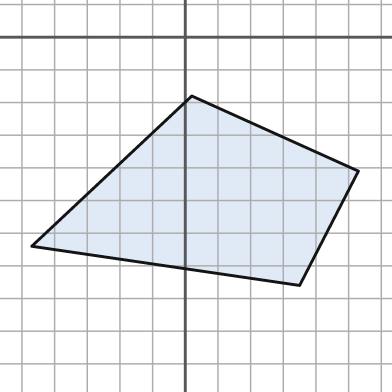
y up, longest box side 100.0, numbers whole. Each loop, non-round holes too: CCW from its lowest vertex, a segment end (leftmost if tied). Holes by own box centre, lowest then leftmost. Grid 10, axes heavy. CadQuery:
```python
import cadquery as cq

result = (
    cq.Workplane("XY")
    .moveTo(35.0, -76.0)
    .lineTo(53.0, -41.0)
    .lineTo(2.0, -18.0)
    .lineTo(-47.0, -64.0)
    .close()
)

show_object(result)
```